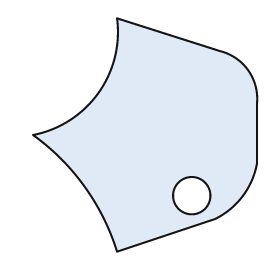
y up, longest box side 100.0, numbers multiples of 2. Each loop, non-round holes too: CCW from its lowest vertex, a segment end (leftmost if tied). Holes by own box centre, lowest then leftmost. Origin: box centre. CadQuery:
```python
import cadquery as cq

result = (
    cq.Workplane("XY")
    .moveTo(-12.0, -50.0)
    .lineTo(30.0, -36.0)
    .threePointArc((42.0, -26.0), (48.0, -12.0))
    .lineTo(48.0, 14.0)
    .threePointArc((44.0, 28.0), (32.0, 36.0))
    .lineTo(-12.0, 50.0)
    .threePointArc((-20.0, 18.0), (-48.0, 0.0))
    .threePointArc((-26.0, -22.0), (-12.0, -50.0))
    .close()
    .moveTo(20.0, -26.0)
    .circle(8.0)
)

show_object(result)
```